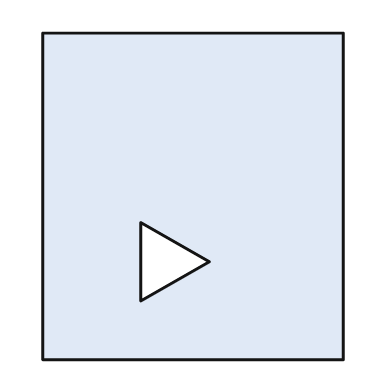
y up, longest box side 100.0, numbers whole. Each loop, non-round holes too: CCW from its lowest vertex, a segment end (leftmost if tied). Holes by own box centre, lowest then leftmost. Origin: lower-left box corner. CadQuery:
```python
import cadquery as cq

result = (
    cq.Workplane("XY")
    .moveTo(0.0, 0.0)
    .lineTo(92.0, 0.0)
    .lineTo(92.0, 100.0)
    .lineTo(0.0, 100.0)
    .close()
    .moveTo(30.0, 18.0)
    .lineTo(51.0, 30.0)
    .lineTo(30.0, 42.0)
    .close()
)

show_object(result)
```